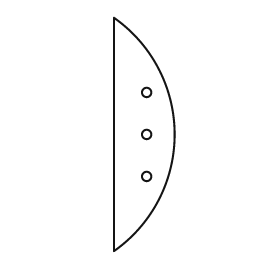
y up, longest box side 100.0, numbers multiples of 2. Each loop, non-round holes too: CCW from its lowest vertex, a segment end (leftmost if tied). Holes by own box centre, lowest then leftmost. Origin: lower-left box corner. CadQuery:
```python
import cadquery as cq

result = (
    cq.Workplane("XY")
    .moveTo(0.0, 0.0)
    .threePointArc((26.0, 50.0), (0.0, 100.0))
    .close()
    .moveTo(14.0, 32.0)
    .circle(2.0)
    .moveTo(14.0, 50.0)
    .circle(2.0)
    .moveTo(14.0, 68.0)
    .circle(2.0)
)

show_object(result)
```